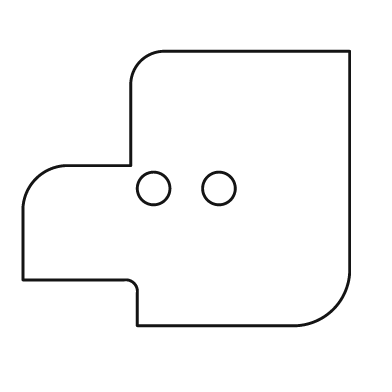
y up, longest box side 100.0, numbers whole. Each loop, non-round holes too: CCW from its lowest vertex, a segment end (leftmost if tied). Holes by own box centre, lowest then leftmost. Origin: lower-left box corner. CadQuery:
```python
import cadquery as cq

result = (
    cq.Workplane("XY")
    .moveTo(35.0, 0.0)
    .lineTo(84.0, 0.0)
    .threePointArc((95.0, 5.0), (100.0, 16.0))
    .lineTo(100.0, 84.0)
    .lineTo(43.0, 84.0)
    .threePointArc((36.0, 81.0), (33.0, 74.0))
    .lineTo(33.0, 49.0)
    .lineTo(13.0, 49.0)
    .threePointArc((4.0, 45.0), (0.0, 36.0))
    .lineTo(0.0, 14.0)
    .lineTo(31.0, 14.0)
    .threePointArc((34.0, 13.0), (35.0, 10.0))
    .close()
    .moveTo(40.0, 42.0)
    .circle(5.0)
    .moveTo(60.0, 42.0)
    .circle(5.0)
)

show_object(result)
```